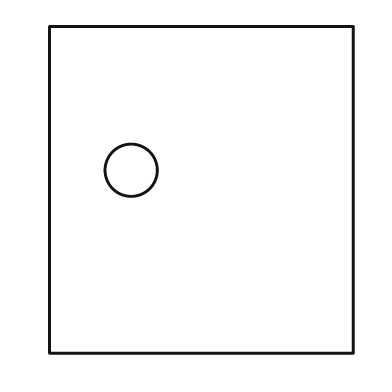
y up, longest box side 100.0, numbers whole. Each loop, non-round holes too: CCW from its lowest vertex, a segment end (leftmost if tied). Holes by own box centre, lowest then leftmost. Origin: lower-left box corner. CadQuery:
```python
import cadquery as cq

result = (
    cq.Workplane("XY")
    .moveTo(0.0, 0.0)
    .lineTo(93.0, 0.0)
    .lineTo(93.0, 100.0)
    .lineTo(0.0, 100.0)
    .close()
    .moveTo(25.0, 56.0)
    .circle(8.0)
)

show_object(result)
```